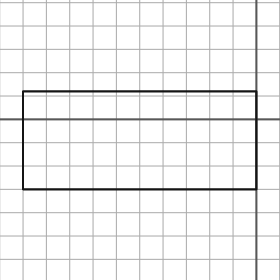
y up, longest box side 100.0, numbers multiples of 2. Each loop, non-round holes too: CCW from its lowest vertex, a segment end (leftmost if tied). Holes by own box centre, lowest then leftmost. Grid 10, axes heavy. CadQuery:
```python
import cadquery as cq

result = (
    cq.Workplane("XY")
    .moveTo(-100.0, -30.0)
    .lineTo(0.0, -30.0)
    .lineTo(0.0, 12.0)
    .lineTo(-100.0, 12.0)
    .close()
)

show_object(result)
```